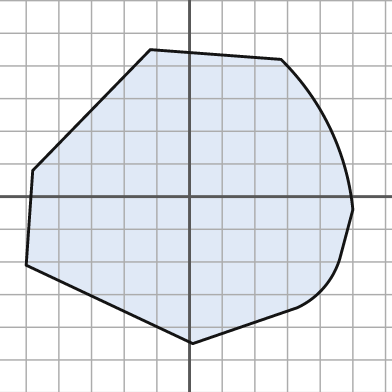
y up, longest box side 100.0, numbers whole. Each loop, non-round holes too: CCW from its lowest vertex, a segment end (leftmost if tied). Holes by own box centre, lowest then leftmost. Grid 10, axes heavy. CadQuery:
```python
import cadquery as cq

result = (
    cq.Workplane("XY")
    .moveTo(1.0, -45.0)
    .lineTo(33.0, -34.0)
    .threePointArc((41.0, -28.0), (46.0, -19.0))
    .lineTo(50.0, -4.0)
    .threePointArc((43.0, 21.0), (28.0, 42.0))
    .lineTo(-12.0, 45.0)
    .lineTo(-48.0, 8.0)
    .lineTo(-50.0, -21.0)
    .close()
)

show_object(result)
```